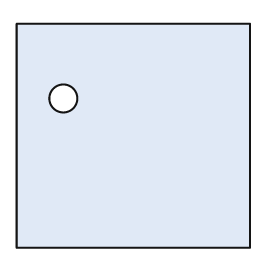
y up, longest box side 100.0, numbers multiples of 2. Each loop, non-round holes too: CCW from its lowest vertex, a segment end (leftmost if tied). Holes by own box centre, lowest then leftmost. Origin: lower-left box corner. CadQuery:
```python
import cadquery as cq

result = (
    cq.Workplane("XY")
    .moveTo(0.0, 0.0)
    .lineTo(100.0, 0.0)
    .lineTo(100.0, 96.0)
    .lineTo(0.0, 96.0)
    .close()
    .moveTo(20.0, 64.0)
    .circle(6.0)
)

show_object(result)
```